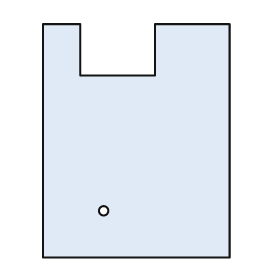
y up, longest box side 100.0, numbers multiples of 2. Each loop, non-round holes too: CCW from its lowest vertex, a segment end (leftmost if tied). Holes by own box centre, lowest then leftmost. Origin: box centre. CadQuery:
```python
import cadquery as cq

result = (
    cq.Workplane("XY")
    .moveTo(-40.0, -50.0)
    .lineTo(40.0, -50.0)
    .lineTo(40.0, 50.0)
    .lineTo(8.0, 50.0)
    .lineTo(8.0, 28.0)
    .lineTo(-24.0, 28.0)
    .lineTo(-24.0, 50.0)
    .lineTo(-40.0, 50.0)
    .close()
    .moveTo(-14.0, -30.0)
    .circle(2.0)
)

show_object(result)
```